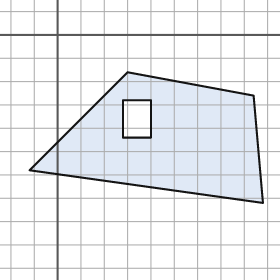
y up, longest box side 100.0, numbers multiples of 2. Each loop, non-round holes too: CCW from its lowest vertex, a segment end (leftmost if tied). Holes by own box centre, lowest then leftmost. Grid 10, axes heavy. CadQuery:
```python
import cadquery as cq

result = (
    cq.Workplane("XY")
    .moveTo(88.0, -72.0)
    .lineTo(84.0, -26.0)
    .lineTo(30.0, -16.0)
    .lineTo(-12.0, -58.0)
    .close()
    .moveTo(28.0, -44.0)
    .lineTo(40.0, -44.0)
    .lineTo(40.0, -28.0)
    .lineTo(28.0, -28.0)
    .close()
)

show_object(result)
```